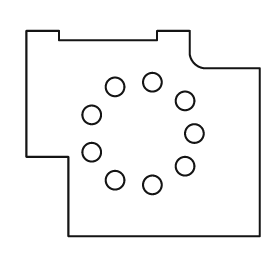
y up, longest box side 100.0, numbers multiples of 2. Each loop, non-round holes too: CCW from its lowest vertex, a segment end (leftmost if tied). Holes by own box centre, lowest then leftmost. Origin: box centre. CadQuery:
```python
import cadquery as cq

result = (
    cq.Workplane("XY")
    .moveTo(-32.0, -44.0)
    .lineTo(50.0, -44.0)
    .lineTo(50.0, 28.0)
    .lineTo(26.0, 28.0)
    .threePointArc((22.0, 30.0), (20.0, 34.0))
    .lineTo(20.0, 44.0)
    .lineTo(6.0, 44.0)
    .lineTo(6.0, 40.0)
    .lineTo(-36.0, 40.0)
    .lineTo(-36.0, 44.0)
    .lineTo(-50.0, 44.0)
    .lineTo(-50.0, -10.0)
    .lineTo(-32.0, -10.0)
    .close()
    .moveTo(4.0, -22.0)
    .circle(4.0)
    .moveTo(-12.0, -20.0)
    .circle(4.0)
    .moveTo(18.0, -14.0)
    .circle(4.0)
    .moveTo(-22.0, -8.0)
    .circle(4.0)
    .moveTo(22.0, 0.0)
    .circle(4.0)
    .moveTo(-22.0, 8.0)
    .circle(4.0)
    .moveTo(18.0, 14.0)
    .circle(4.0)
    .moveTo(-12.0, 20.0)
    .circle(4.0)
    .moveTo(4.0, 22.0)
    .circle(4.0)
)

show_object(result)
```